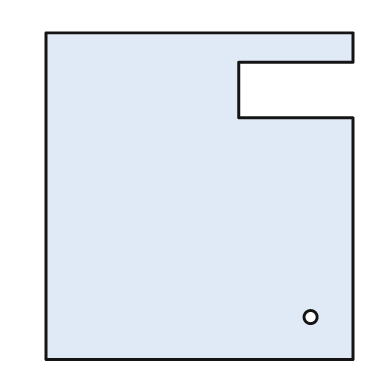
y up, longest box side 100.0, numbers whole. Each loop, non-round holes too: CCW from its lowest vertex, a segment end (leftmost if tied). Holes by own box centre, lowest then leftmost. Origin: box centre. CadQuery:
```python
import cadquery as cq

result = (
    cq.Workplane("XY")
    .moveTo(-47.0, -50.0)
    .lineTo(47.0, -50.0)
    .lineTo(47.0, 24.0)
    .lineTo(12.0, 24.0)
    .lineTo(12.0, 41.0)
    .lineTo(47.0, 41.0)
    .lineTo(47.0, 50.0)
    .lineTo(-47.0, 50.0)
    .close()
    .moveTo(34.0, -37.0)
    .circle(2.0)
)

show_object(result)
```